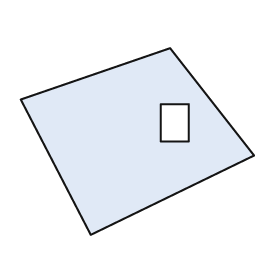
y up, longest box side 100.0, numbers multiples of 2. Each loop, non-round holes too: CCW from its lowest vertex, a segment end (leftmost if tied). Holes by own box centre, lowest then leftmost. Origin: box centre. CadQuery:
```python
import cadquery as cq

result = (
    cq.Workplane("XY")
    .moveTo(-20.0, -40.0)
    .lineTo(50.0, -6.0)
    .lineTo(14.0, 40.0)
    .lineTo(-50.0, 18.0)
    .close()
    .moveTo(10.0, 0.0)
    .lineTo(22.0, 0.0)
    .lineTo(22.0, 16.0)
    .lineTo(10.0, 16.0)
    .close()
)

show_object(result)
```